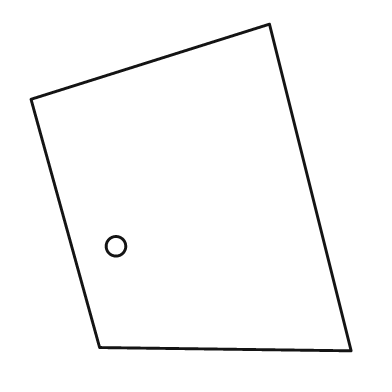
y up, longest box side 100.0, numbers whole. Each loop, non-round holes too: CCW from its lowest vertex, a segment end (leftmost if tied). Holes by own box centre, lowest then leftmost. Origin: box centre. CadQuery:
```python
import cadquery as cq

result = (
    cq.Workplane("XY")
    .moveTo(49.0, -50.0)
    .lineTo(24.0, 50.0)
    .lineTo(-49.0, 27.0)
    .lineTo(-28.0, -49.0)
    .close()
    .moveTo(-23.0, -18.0)
    .circle(3.0)
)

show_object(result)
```